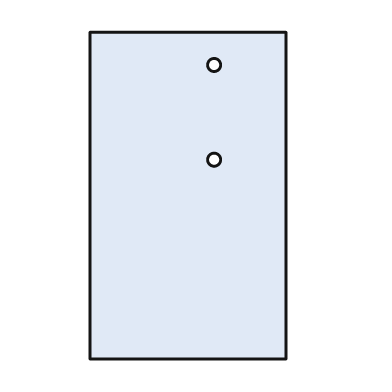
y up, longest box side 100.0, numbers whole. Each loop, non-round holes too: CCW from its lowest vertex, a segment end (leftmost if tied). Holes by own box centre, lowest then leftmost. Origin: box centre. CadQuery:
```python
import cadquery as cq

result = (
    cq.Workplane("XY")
    .moveTo(-30.0, -50.0)
    .lineTo(30.0, -50.0)
    .lineTo(30.0, 50.0)
    .lineTo(-30.0, 50.0)
    .close()
    .moveTo(8.0, 11.0)
    .circle(2.0)
    .moveTo(8.0, 40.0)
    .circle(2.0)
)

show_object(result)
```